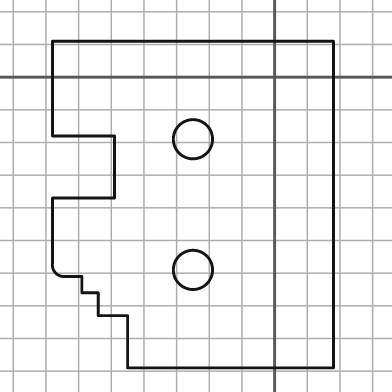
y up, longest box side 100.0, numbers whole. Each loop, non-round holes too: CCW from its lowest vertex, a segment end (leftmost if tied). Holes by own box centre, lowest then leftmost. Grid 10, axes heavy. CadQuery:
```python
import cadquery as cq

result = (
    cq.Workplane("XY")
    .moveTo(-45.0, -89.0)
    .lineTo(18.0, -89.0)
    .lineTo(18.0, 11.0)
    .lineTo(-68.0, 11.0)
    .lineTo(-68.0, -18.0)
    .lineTo(-49.0, -18.0)
    .lineTo(-49.0, -37.0)
    .lineTo(-68.0, -37.0)
    .lineTo(-68.0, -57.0)
    .threePointArc((-67.0, -60.0), (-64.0, -61.0))
    .lineTo(-59.0, -61.0)
    .lineTo(-59.0, -66.0)
    .lineTo(-54.0, -66.0)
    .lineTo(-54.0, -73.0)
    .lineTo(-45.0, -73.0)
    .close()
    .moveTo(-25.0, -59.0)
    .circle(6.0)
    .moveTo(-25.0, -19.0)
    .circle(6.0)
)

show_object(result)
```